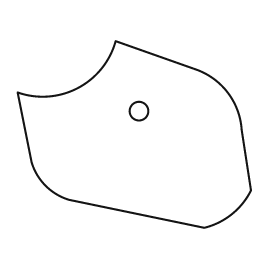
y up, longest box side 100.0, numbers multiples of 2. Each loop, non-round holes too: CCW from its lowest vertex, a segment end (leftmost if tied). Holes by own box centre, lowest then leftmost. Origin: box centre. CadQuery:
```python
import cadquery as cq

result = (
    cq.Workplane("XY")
    .moveTo(30.0, -40.0)
    .threePointArc((42.0, -34.0), (50.0, -24.0))
    .lineTo(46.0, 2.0)
    .threePointArc((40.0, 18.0), (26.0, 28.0))
    .lineTo(-8.0, 40.0)
    .threePointArc((-24.0, 20.0), (-50.0, 18.0))
    .lineTo(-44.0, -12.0)
    .threePointArc((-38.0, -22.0), (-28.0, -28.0))
    .close()
    .moveTo(2.0, 10.0)
    .circle(4.0)
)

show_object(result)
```